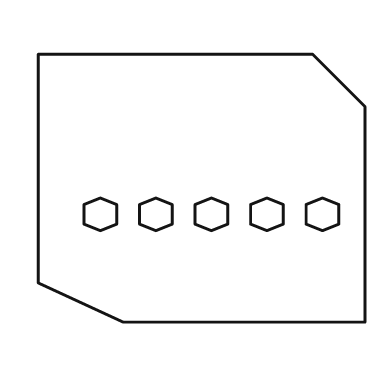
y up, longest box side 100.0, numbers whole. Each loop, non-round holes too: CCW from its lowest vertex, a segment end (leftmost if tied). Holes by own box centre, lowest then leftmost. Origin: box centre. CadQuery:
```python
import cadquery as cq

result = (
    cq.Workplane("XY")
    .moveTo(-24.0, -41.0)
    .lineTo(50.0, -41.0)
    .lineTo(50.0, 25.0)
    .lineTo(34.0, 41.0)
    .lineTo(-50.0, 41.0)
    .lineTo(-50.0, -29.0)
    .close()
    .moveTo(-31.0, -13.0)
    .lineTo(-26.0, -11.0)
    .lineTo(-26.0, -5.0)
    .lineTo(-31.0, -3.0)
    .lineTo(-36.0, -5.0)
    .lineTo(-36.0, -11.0)
    .close()
    .moveTo(-14.0, -13.0)
    .lineTo(-9.0, -11.0)
    .lineTo(-9.0, -5.0)
    .lineTo(-14.0, -3.0)
    .lineTo(-19.0, -5.0)
    .lineTo(-19.0, -11.0)
    .close()
    .moveTo(3.0, -13.0)
    .lineTo(8.0, -11.0)
    .lineTo(8.0, -5.0)
    .lineTo(3.0, -3.0)
    .lineTo(-2.0, -5.0)
    .lineTo(-2.0, -11.0)
    .close()
    .moveTo(20.0, -13.0)
    .lineTo(25.0, -11.0)
    .lineTo(25.0, -5.0)
    .lineTo(20.0, -3.0)
    .lineTo(15.0, -5.0)
    .lineTo(15.0, -11.0)
    .close()
    .moveTo(37.0, -13.0)
    .lineTo(42.0, -11.0)
    .lineTo(42.0, -5.0)
    .lineTo(37.0, -3.0)
    .lineTo(32.0, -5.0)
    .lineTo(32.0, -11.0)
    .close()
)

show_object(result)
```